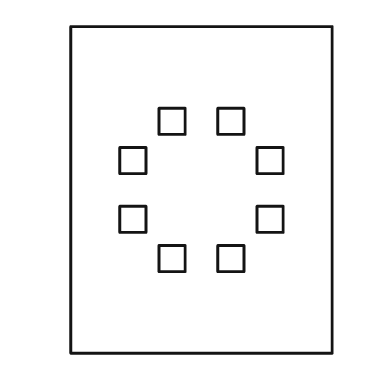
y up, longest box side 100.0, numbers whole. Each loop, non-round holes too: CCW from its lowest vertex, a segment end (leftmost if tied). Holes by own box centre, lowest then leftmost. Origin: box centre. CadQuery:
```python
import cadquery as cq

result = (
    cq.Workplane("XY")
    .moveTo(-40.0, -50.0)
    .lineTo(40.0, -50.0)
    .lineTo(40.0, 50.0)
    .lineTo(-40.0, 50.0)
    .close()
    .moveTo(-13.0, -25.0)
    .lineTo(-5.0, -25.0)
    .lineTo(-5.0, -17.0)
    .lineTo(-13.0, -17.0)
    .close()
    .moveTo(5.0, -25.0)
    .lineTo(13.0, -25.0)
    .lineTo(13.0, -17.0)
    .lineTo(5.0, -17.0)
    .close()
    .moveTo(-25.0, -13.0)
    .lineTo(-17.0, -13.0)
    .lineTo(-17.0, -5.0)
    .lineTo(-25.0, -5.0)
    .close()
    .moveTo(17.0, -13.0)
    .lineTo(25.0, -13.0)
    .lineTo(25.0, -5.0)
    .lineTo(17.0, -5.0)
    .close()
    .moveTo(-25.0, 5.0)
    .lineTo(-17.0, 5.0)
    .lineTo(-17.0, 13.0)
    .lineTo(-25.0, 13.0)
    .close()
    .moveTo(17.0, 5.0)
    .lineTo(25.0, 5.0)
    .lineTo(25.0, 13.0)
    .lineTo(17.0, 13.0)
    .close()
    .moveTo(-13.0, 17.0)
    .lineTo(-5.0, 17.0)
    .lineTo(-5.0, 25.0)
    .lineTo(-13.0, 25.0)
    .close()
    .moveTo(5.0, 17.0)
    .lineTo(13.0, 17.0)
    .lineTo(13.0, 25.0)
    .lineTo(5.0, 25.0)
    .close()
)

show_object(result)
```